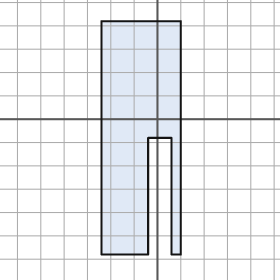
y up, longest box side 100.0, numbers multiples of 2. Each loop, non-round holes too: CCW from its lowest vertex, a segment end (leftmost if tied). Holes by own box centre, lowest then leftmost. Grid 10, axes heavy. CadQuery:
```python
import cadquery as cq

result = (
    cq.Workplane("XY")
    .moveTo(-24.0, -58.0)
    .lineTo(-4.0, -58.0)
    .lineTo(-4.0, -8.0)
    .lineTo(6.0, -8.0)
    .lineTo(6.0, -58.0)
    .lineTo(10.0, -58.0)
    .lineTo(10.0, 42.0)
    .lineTo(-24.0, 42.0)
    .close()
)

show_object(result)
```